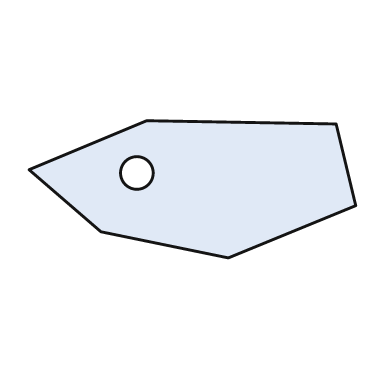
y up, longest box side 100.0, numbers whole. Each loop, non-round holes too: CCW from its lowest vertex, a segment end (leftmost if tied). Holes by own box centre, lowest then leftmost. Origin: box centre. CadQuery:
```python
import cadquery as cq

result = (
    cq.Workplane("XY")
    .moveTo(11.0, -21.0)
    .lineTo(50.0, -5.0)
    .lineTo(44.0, 20.0)
    .lineTo(-14.0, 21.0)
    .lineTo(-50.0, 6.0)
    .lineTo(-28.0, -13.0)
    .close()
    .moveTo(-17.0, 5.0)
    .circle(5.0)
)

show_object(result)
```